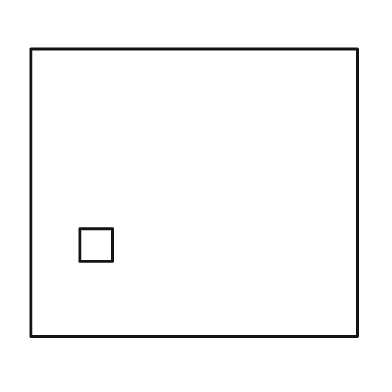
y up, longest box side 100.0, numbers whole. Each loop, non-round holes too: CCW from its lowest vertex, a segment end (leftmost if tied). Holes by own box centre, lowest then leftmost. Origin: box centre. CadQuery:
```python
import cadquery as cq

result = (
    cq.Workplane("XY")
    .moveTo(-50.0, -44.0)
    .lineTo(50.0, -44.0)
    .lineTo(50.0, 44.0)
    .lineTo(-50.0, 44.0)
    .close()
    .moveTo(-35.0, -21.0)
    .lineTo(-25.0, -21.0)
    .lineTo(-25.0, -11.0)
    .lineTo(-35.0, -11.0)
    .close()
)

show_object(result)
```